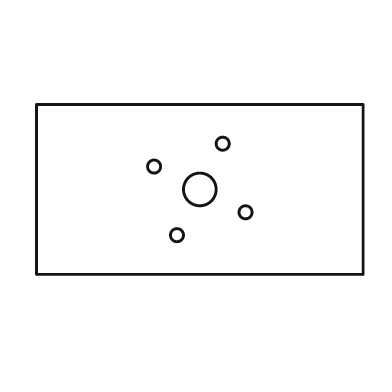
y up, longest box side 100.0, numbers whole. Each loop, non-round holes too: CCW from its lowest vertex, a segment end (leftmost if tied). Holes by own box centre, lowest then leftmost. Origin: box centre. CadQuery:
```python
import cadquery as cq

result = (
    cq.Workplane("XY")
    .moveTo(-50.0, -26.0)
    .lineTo(50.0, -26.0)
    .lineTo(50.0, 26.0)
    .lineTo(-50.0, 26.0)
    .close()
    .moveTo(-7.0, -14.0)
    .circle(2.0)
    .moveTo(14.0, -7.0)
    .circle(2.0)
    .moveTo(0.0, 0.0)
    .circle(5.0)
    .moveTo(-14.0, 7.0)
    .circle(2.0)
    .moveTo(7.0, 14.0)
    .circle(2.0)
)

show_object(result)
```